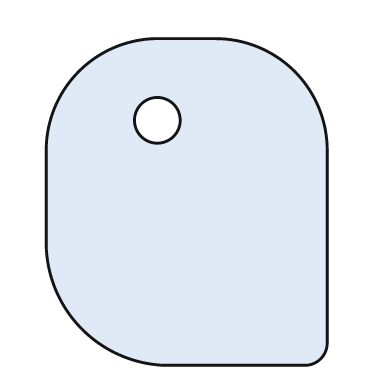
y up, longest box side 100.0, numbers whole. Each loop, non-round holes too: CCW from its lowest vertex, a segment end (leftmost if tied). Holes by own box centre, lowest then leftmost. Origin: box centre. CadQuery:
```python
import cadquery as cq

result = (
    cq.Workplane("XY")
    .moveTo(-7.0, -50.0)
    .lineTo(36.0, -50.0)
    .threePointArc((41.0, -48.0), (43.0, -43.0))
    .lineTo(43.0, 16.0)
    .threePointArc((33.0, 40.0), (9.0, 50.0))
    .lineTo(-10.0, 50.0)
    .threePointArc((-33.0, 40.0), (-43.0, 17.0))
    .lineTo(-43.0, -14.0)
    .threePointArc((-32.0, -39.0), (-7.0, -50.0))
    .close()
    .moveTo(-9.0, 25.0)
    .circle(7.0)
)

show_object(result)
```